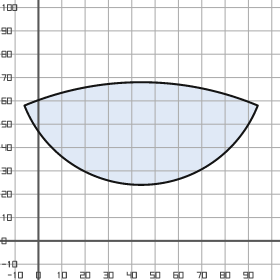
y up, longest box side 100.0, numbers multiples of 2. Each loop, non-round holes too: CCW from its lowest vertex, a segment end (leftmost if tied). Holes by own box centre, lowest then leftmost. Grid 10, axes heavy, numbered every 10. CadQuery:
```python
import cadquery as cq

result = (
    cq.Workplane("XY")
    .moveTo(-6.0, 58.0)
    .threePointArc((44.0, 24.0), (94.0, 58.0))
    .threePointArc((44.0, 68.0), (-6.0, 58.0))
    .close()
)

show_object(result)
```